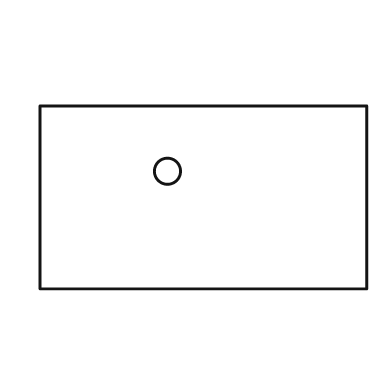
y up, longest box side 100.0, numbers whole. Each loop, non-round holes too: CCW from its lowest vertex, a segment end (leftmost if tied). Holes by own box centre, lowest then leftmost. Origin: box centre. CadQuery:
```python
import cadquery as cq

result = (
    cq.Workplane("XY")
    .moveTo(-50.0, -28.0)
    .lineTo(50.0, -28.0)
    .lineTo(50.0, 28.0)
    .lineTo(-50.0, 28.0)
    .close()
    .moveTo(-11.0, 8.0)
    .circle(4.0)
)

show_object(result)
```